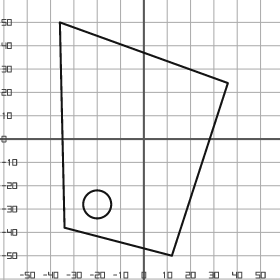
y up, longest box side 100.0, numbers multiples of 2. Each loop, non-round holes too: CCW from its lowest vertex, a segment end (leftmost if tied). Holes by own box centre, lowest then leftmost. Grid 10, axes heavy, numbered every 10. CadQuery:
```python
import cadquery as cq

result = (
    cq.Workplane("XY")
    .moveTo(12.0, -50.0)
    .lineTo(36.0, 24.0)
    .lineTo(-36.0, 50.0)
    .lineTo(-34.0, -38.0)
    .close()
    .moveTo(-20.0, -28.0)
    .circle(6.0)
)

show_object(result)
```